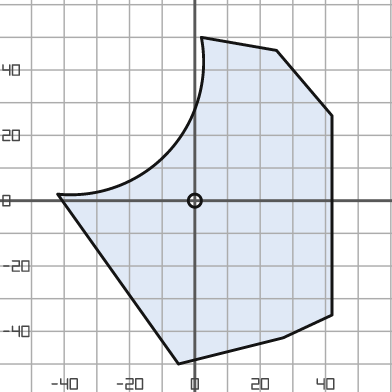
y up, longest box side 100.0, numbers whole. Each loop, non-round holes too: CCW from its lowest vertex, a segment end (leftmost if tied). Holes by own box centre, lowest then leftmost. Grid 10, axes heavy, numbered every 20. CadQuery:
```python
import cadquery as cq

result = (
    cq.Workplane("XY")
    .moveTo(-5.0, -50.0)
    .lineTo(27.0, -42.0)
    .lineTo(42.0, -35.0)
    .lineTo(42.0, 26.0)
    .lineTo(25.0, 46.0)
    .lineTo(2.0, 50.0)
    .threePointArc((-8.0, 15.0), (-42.0, 2.0))
    .close()
    .moveTo(0.0, 0.0)
    .circle(2.0)
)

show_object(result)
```